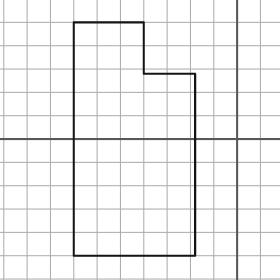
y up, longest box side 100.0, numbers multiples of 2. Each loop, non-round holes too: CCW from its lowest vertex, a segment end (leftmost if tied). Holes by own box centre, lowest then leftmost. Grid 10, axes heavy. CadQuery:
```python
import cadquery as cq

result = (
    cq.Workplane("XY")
    .moveTo(-70.0, -50.0)
    .lineTo(-18.0, -50.0)
    .lineTo(-18.0, 28.0)
    .lineTo(-40.0, 28.0)
    .lineTo(-40.0, 50.0)
    .lineTo(-70.0, 50.0)
    .close()
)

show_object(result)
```